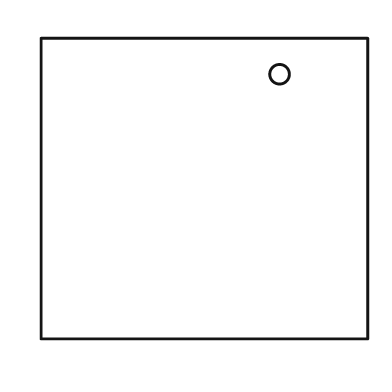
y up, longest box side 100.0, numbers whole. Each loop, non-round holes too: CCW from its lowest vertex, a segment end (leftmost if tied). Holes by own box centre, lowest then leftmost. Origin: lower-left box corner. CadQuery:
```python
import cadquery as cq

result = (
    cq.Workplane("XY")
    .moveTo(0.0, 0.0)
    .lineTo(100.0, 0.0)
    .lineTo(100.0, 92.0)
    .lineTo(0.0, 92.0)
    .close()
    .moveTo(73.0, 81.0)
    .circle(3.0)
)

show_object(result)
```